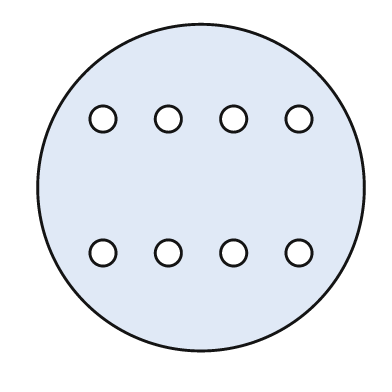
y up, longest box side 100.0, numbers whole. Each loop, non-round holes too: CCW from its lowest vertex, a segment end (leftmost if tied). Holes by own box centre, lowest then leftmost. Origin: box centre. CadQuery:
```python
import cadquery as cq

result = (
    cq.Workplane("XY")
    .moveTo(0.0, 0.0)
    .circle(50.0)
    .moveTo(-30.0, -20.0)
    .circle(4.0)
    .moveTo(-10.0, -20.0)
    .circle(4.0)
    .moveTo(10.0, -20.0)
    .circle(4.0)
    .moveTo(30.0, -20.0)
    .circle(4.0)
    .moveTo(-30.0, 21.0)
    .circle(4.0)
    .moveTo(-10.0, 21.0)
    .circle(4.0)
    .moveTo(10.0, 21.0)
    .circle(4.0)
    .moveTo(30.0, 21.0)
    .circle(4.0)
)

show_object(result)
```